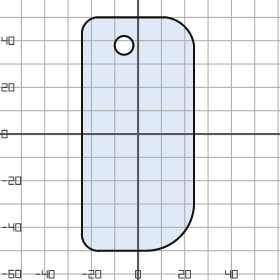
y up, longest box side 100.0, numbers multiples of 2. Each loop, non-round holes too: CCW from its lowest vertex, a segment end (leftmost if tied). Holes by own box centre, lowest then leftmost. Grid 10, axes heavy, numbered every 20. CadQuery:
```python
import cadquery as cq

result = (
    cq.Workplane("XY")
    .moveTo(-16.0, -50.0)
    .lineTo(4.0, -50.0)
    .threePointArc((18.0, -44.0), (24.0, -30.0))
    .lineTo(24.0, 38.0)
    .threePointArc((20.0, 46.0), (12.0, 50.0))
    .lineTo(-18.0, 50.0)
    .threePointArc((-22.0, 48.0), (-24.0, 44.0))
    .lineTo(-24.0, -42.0)
    .threePointArc((-22.0, -48.0), (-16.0, -50.0))
    .close()
    .moveTo(-6.0, 38.0)
    .circle(4.0)
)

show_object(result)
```